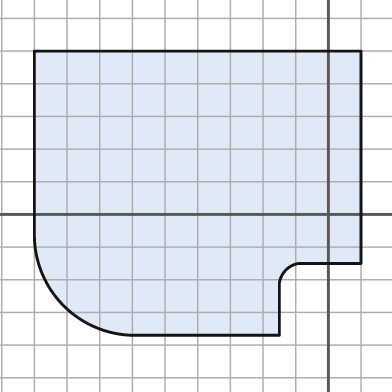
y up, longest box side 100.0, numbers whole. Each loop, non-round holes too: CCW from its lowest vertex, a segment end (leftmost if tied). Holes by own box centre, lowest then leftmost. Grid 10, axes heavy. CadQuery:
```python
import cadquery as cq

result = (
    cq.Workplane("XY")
    .moveTo(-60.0, -37.0)
    .lineTo(-15.0, -37.0)
    .lineTo(-15.0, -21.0)
    .threePointArc((-13.0, -17.0), (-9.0, -15.0))
    .lineTo(10.0, -15.0)
    .lineTo(10.0, 50.0)
    .lineTo(-90.0, 50.0)
    .lineTo(-90.0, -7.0)
    .threePointArc((-81.0, -28.0), (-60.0, -37.0))
    .close()
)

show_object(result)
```